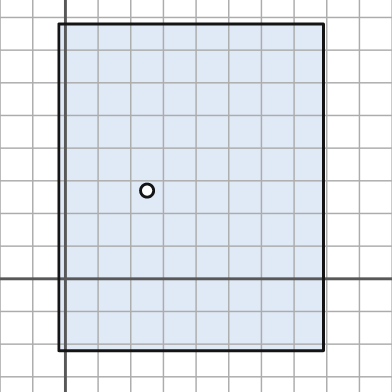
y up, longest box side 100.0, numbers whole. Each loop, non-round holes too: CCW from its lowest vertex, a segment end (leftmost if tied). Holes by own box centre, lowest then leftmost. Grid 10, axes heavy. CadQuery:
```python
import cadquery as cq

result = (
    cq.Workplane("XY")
    .moveTo(-2.0, -22.0)
    .lineTo(79.0, -22.0)
    .lineTo(79.0, 78.0)
    .lineTo(-2.0, 78.0)
    .close()
    .moveTo(25.0, 27.0)
    .circle(2.0)
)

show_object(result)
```